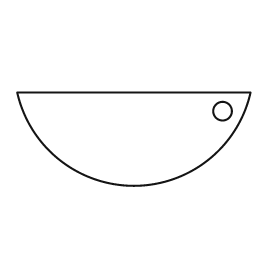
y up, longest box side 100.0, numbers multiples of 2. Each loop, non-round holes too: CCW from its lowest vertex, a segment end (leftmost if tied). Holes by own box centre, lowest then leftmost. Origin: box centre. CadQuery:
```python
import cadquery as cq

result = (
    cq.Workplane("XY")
    .moveTo(-50.0, 20.0)
    .threePointArc((0.0, -20.0), (50.0, 20.0))
    .close()
    .moveTo(38.0, 12.0)
    .circle(4.0)
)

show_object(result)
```